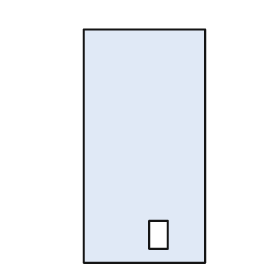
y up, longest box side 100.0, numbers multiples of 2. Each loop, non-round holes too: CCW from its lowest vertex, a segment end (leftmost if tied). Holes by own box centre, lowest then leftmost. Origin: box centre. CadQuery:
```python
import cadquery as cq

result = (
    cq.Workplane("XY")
    .moveTo(-26.0, -50.0)
    .lineTo(26.0, -50.0)
    .lineTo(26.0, 50.0)
    .lineTo(-26.0, 50.0)
    .close()
    .moveTo(2.0, -44.0)
    .lineTo(10.0, -44.0)
    .lineTo(10.0, -32.0)
    .lineTo(2.0, -32.0)
    .close()
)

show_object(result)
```